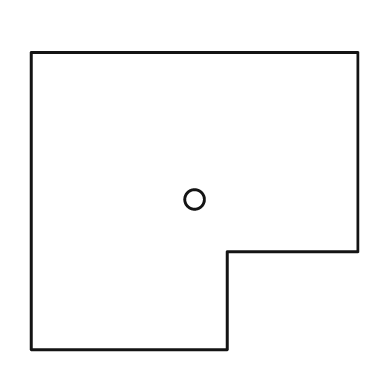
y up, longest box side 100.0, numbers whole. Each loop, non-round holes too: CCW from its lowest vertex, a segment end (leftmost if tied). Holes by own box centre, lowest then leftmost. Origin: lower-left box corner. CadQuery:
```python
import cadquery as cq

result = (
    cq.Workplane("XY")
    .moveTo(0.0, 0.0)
    .lineTo(60.0, 0.0)
    .lineTo(60.0, 30.0)
    .lineTo(100.0, 30.0)
    .lineTo(100.0, 91.0)
    .lineTo(0.0, 91.0)
    .close()
    .moveTo(50.0, 46.0)
    .circle(3.0)
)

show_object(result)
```